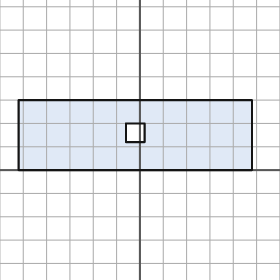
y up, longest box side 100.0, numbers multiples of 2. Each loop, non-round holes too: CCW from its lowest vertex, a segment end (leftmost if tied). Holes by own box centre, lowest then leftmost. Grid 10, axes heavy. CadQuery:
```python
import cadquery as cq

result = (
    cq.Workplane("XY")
    .moveTo(-52.0, 0.0)
    .lineTo(48.0, 0.0)
    .lineTo(48.0, 30.0)
    .lineTo(-52.0, 30.0)
    .close()
    .moveTo(-6.0, 12.0)
    .lineTo(2.0, 12.0)
    .lineTo(2.0, 20.0)
    .lineTo(-6.0, 20.0)
    .close()
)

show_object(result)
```